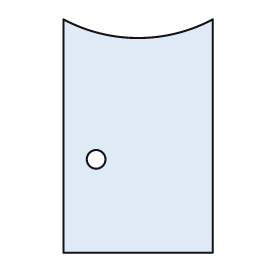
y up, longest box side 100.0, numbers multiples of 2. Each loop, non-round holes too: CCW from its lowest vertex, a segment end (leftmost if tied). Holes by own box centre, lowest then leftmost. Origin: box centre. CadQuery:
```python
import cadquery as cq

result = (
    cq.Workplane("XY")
    .moveTo(-32.0, -50.0)
    .lineTo(32.0, -50.0)
    .lineTo(32.0, 50.0)
    .threePointArc((0.0, 42.0), (-32.0, 50.0))
    .close()
    .moveTo(-18.0, -10.0)
    .circle(4.0)
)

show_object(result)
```